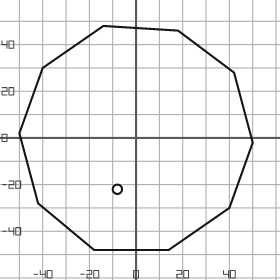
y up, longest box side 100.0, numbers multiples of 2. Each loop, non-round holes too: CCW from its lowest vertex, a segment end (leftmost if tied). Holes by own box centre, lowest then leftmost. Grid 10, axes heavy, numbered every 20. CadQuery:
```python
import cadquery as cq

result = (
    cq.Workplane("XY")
    .moveTo(-18.0, -48.0)
    .lineTo(14.0, -48.0)
    .lineTo(40.0, -30.0)
    .lineTo(50.0, -2.0)
    .lineTo(42.0, 28.0)
    .lineTo(18.0, 46.0)
    .lineTo(-14.0, 48.0)
    .lineTo(-40.0, 30.0)
    .lineTo(-50.0, 2.0)
    .lineTo(-42.0, -28.0)
    .close()
    .moveTo(-8.0, -22.0)
    .circle(2.0)
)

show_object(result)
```